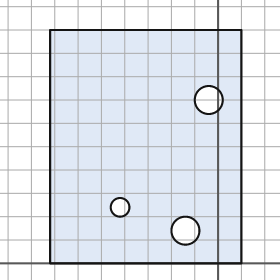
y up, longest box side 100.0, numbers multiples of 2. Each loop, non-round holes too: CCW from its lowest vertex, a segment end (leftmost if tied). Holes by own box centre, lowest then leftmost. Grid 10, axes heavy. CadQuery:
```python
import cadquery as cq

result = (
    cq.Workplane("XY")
    .moveTo(-72.0, 0.0)
    .lineTo(10.0, 0.0)
    .lineTo(10.0, 100.0)
    .lineTo(-72.0, 100.0)
    .close()
    .moveTo(-14.0, 14.0)
    .circle(6.0)
    .moveTo(-42.0, 24.0)
    .circle(4.0)
    .moveTo(-4.0, 70.0)
    .circle(6.0)
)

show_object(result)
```